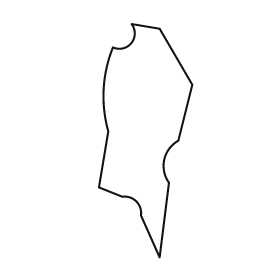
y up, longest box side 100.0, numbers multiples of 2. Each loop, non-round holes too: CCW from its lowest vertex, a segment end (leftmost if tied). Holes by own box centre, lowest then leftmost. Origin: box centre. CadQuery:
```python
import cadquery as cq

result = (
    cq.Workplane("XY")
    .moveTo(6.0, -50.0)
    .lineTo(10.0, -18.0)
    .threePointArc((8.0, -8.0), (14.0, 0.0))
    .lineTo(20.0, 24.0)
    .lineTo(6.0, 48.0)
    .lineTo(-6.0, 50.0)
    .threePointArc((-6.0, 42.0), (-14.0, 40.0))
    .threePointArc((-18.0, 22.0), (-16.0, 4.0))
    .lineTo(-20.0, -20.0)
    .lineTo(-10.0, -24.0)
    .threePointArc((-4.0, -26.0), (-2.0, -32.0))
    .close()
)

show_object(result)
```